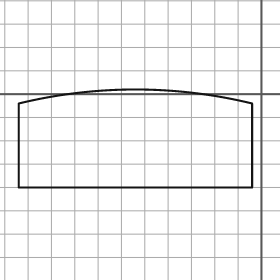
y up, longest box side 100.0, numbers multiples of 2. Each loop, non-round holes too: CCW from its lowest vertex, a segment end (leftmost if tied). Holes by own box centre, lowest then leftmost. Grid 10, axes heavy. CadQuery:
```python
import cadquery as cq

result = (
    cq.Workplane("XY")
    .moveTo(-104.0, -40.0)
    .lineTo(-4.0, -40.0)
    .lineTo(-4.0, -4.0)
    .threePointArc((-54.0, 2.0), (-104.0, -4.0))
    .close()
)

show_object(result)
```